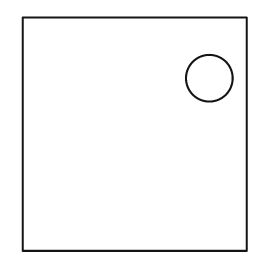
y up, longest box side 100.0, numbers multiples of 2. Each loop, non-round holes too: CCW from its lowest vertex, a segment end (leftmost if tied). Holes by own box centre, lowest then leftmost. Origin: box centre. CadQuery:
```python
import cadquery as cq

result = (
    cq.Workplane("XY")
    .moveTo(-48.0, -50.0)
    .lineTo(48.0, -50.0)
    .lineTo(48.0, 50.0)
    .lineTo(-48.0, 50.0)
    .close()
    .moveTo(32.0, 24.0)
    .circle(10.0)
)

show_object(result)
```